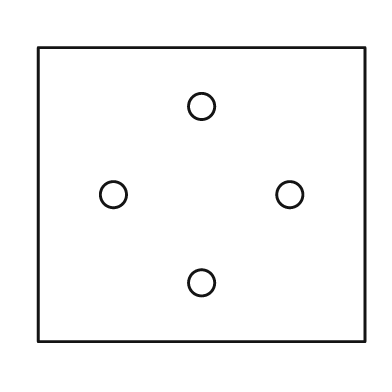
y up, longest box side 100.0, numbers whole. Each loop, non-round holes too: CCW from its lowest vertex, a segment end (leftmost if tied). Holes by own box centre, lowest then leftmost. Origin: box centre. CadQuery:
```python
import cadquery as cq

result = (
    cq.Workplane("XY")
    .moveTo(-50.0, -45.0)
    .lineTo(50.0, -45.0)
    .lineTo(50.0, 45.0)
    .lineTo(-50.0, 45.0)
    .close()
    .moveTo(0.0, -27.0)
    .circle(4.0)
    .moveTo(-27.0, 0.0)
    .circle(4.0)
    .moveTo(27.0, 0.0)
    .circle(4.0)
    .moveTo(0.0, 27.0)
    .circle(4.0)
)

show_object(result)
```